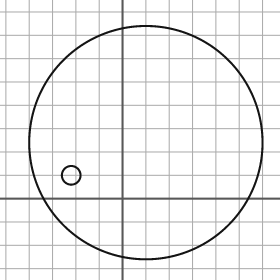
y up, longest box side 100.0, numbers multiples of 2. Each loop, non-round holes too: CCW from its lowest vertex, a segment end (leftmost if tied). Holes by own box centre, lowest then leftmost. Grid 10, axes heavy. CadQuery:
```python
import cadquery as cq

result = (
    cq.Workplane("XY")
    .moveTo(10.0, 24.0)
    .circle(50.0)
    .moveTo(-22.0, 10.0)
    .circle(4.0)
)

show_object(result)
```